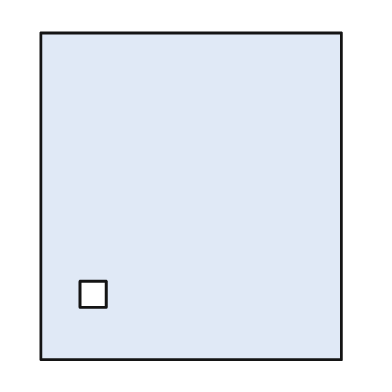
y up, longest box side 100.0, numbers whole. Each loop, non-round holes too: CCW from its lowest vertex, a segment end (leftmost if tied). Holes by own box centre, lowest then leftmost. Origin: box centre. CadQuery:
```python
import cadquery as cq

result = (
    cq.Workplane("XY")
    .moveTo(-46.0, -50.0)
    .lineTo(46.0, -50.0)
    .lineTo(46.0, 50.0)
    .lineTo(-46.0, 50.0)
    .close()
    .moveTo(-34.0, -34.0)
    .lineTo(-26.0, -34.0)
    .lineTo(-26.0, -26.0)
    .lineTo(-34.0, -26.0)
    .close()
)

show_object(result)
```